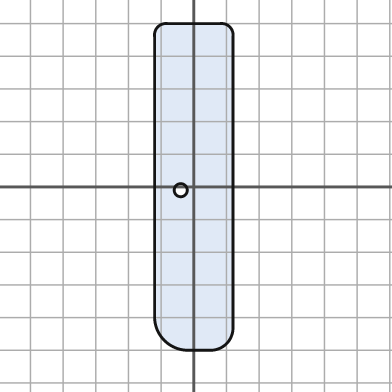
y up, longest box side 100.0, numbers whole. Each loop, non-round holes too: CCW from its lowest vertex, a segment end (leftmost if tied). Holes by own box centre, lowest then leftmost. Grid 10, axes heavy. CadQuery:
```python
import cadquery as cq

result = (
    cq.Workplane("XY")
    .moveTo(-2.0, -50.0)
    .lineTo(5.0, -50.0)
    .threePointArc((10.0, -48.0), (12.0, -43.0))
    .lineTo(12.0, 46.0)
    .threePointArc((11.0, 49.0), (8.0, 50.0))
    .lineTo(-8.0, 50.0)
    .threePointArc((-11.0, 49.0), (-12.0, 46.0))
    .lineTo(-12.0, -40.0)
    .threePointArc((-9.0, -47.0), (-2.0, -50.0))
    .close()
    .moveTo(-4.0, -1.0)
    .circle(2.0)
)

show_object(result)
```